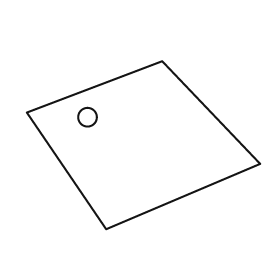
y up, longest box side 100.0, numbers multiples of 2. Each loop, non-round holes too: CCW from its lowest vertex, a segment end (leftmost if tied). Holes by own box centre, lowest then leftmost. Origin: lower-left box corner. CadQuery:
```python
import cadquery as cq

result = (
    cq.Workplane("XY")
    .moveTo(34.0, 0.0)
    .lineTo(100.0, 28.0)
    .lineTo(58.0, 72.0)
    .lineTo(0.0, 50.0)
    .close()
    .moveTo(26.0, 48.0)
    .circle(4.0)
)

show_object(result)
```